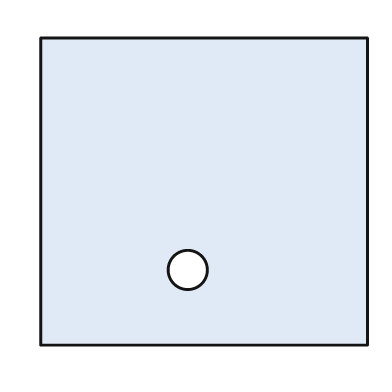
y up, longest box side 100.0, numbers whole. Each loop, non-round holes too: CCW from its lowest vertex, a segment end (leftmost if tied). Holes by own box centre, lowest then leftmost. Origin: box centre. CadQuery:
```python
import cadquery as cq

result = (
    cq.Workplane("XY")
    .moveTo(-50.0, -47.0)
    .lineTo(50.0, -47.0)
    .lineTo(50.0, 47.0)
    .lineTo(-50.0, 47.0)
    .close()
    .moveTo(-5.0, -24.0)
    .circle(6.0)
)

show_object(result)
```